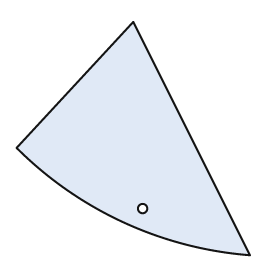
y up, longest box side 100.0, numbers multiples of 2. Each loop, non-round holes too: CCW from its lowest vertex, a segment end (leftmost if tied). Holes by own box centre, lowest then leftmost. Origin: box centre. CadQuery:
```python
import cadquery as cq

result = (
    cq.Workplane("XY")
    .moveTo(50.0, -50.0)
    .lineTo(0.0, 50.0)
    .lineTo(-50.0, -4.0)
    .threePointArc((-4.0, -36.0), (50.0, -50.0))
    .close()
    .moveTo(4.0, -30.0)
    .circle(2.0)
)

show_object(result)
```